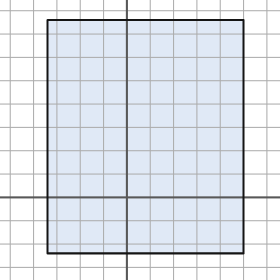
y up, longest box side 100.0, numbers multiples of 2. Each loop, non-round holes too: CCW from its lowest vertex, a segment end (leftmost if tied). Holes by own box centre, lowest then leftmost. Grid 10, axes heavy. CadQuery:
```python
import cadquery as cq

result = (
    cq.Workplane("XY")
    .moveTo(-34.0, -24.0)
    .lineTo(50.0, -24.0)
    .lineTo(50.0, 76.0)
    .lineTo(-34.0, 76.0)
    .close()
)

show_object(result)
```